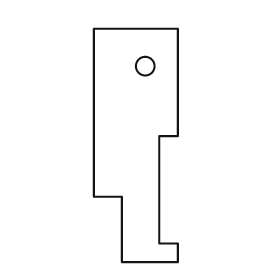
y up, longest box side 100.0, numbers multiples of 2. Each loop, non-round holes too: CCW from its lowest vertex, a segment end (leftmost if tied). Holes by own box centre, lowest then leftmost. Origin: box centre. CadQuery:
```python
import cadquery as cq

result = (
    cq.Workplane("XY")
    .moveTo(-6.0, -50.0)
    .lineTo(18.0, -50.0)
    .lineTo(18.0, -42.0)
    .lineTo(10.0, -42.0)
    .lineTo(10.0, 4.0)
    .lineTo(18.0, 4.0)
    .lineTo(18.0, 50.0)
    .lineTo(-18.0, 50.0)
    .lineTo(-18.0, -22.0)
    .lineTo(-6.0, -22.0)
    .close()
    .moveTo(4.0, 34.0)
    .circle(4.0)
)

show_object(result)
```